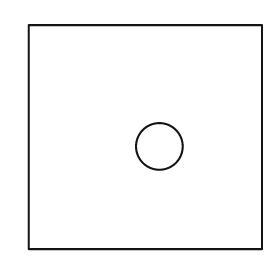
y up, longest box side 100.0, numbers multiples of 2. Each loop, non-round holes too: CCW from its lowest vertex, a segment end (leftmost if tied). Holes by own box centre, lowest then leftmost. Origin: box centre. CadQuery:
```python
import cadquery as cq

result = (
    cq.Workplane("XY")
    .moveTo(-50.0, -48.0)
    .lineTo(50.0, -48.0)
    .lineTo(50.0, 48.0)
    .lineTo(-50.0, 48.0)
    .close()
    .moveTo(6.0, -4.0)
    .circle(10.0)
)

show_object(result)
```